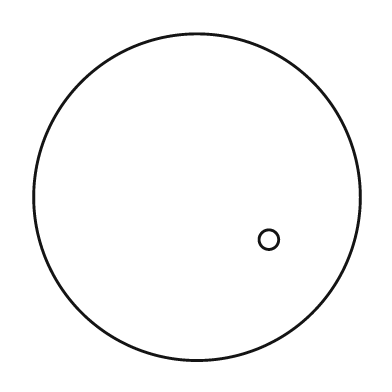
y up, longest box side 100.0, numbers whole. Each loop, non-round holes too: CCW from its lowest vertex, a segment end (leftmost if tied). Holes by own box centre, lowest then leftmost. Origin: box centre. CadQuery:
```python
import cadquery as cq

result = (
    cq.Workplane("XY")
    .moveTo(0.0, 0.0)
    .circle(50.0)
    .moveTo(22.0, -13.0)
    .circle(3.0)
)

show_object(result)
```